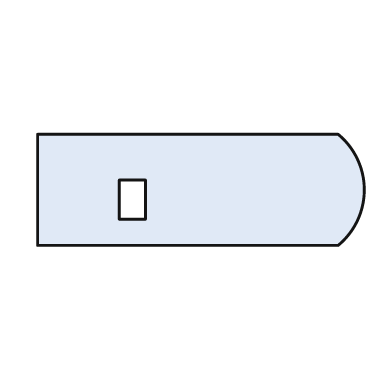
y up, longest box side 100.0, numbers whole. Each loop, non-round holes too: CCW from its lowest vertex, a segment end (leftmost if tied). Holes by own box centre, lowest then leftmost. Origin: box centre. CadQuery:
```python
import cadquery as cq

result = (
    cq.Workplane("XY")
    .moveTo(-50.0, -17.0)
    .lineTo(42.0, -17.0)
    .threePointArc((50.0, 0.0), (42.0, 17.0))
    .lineTo(-50.0, 17.0)
    .close()
    .moveTo(-25.0, -9.0)
    .lineTo(-17.0, -9.0)
    .lineTo(-17.0, 3.0)
    .lineTo(-25.0, 3.0)
    .close()
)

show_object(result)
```